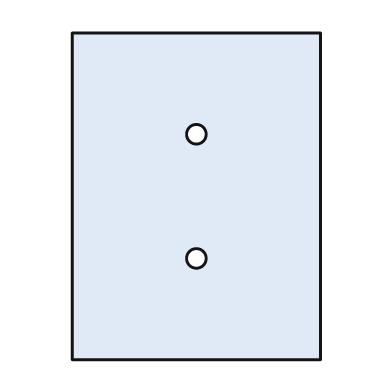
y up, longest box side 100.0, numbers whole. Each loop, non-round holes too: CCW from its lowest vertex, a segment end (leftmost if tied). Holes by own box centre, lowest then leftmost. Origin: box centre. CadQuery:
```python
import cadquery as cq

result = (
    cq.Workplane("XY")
    .moveTo(-38.0, -50.0)
    .lineTo(38.0, -50.0)
    .lineTo(38.0, 50.0)
    .lineTo(-38.0, 50.0)
    .close()
    .moveTo(0.0, -19.0)
    .circle(3.0)
    .moveTo(0.0, 19.0)
    .circle(3.0)
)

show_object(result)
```